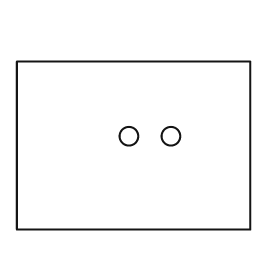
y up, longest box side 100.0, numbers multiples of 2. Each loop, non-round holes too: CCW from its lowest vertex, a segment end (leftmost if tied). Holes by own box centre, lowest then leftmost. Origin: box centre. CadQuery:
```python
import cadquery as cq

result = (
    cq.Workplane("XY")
    .moveTo(-50.0, -36.0)
    .lineTo(50.0, -36.0)
    .lineTo(50.0, 36.0)
    .lineTo(-50.0, 36.0)
    .close()
    .moveTo(-2.0, 4.0)
    .circle(4.0)
    .moveTo(16.0, 4.0)
    .circle(4.0)
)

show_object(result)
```